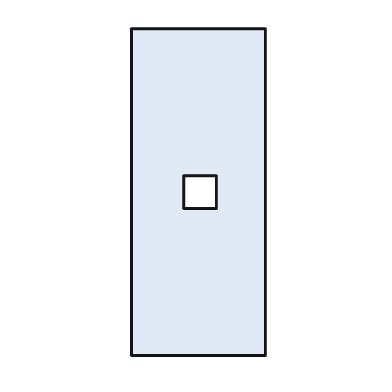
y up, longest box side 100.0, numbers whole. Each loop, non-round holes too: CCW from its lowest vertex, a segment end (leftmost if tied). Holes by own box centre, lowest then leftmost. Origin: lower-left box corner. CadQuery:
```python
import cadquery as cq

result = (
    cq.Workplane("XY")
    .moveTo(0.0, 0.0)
    .lineTo(41.0, 0.0)
    .lineTo(41.0, 100.0)
    .lineTo(0.0, 100.0)
    .close()
    .moveTo(16.0, 45.0)
    .lineTo(26.0, 45.0)
    .lineTo(26.0, 55.0)
    .lineTo(16.0, 55.0)
    .close()
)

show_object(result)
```